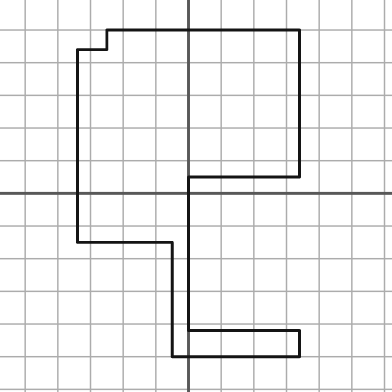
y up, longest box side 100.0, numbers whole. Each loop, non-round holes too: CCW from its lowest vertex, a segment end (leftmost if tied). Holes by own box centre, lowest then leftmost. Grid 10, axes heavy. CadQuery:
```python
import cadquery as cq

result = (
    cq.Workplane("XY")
    .moveTo(-5.0, -50.0)
    .lineTo(34.0, -50.0)
    .lineTo(34.0, -42.0)
    .lineTo(0.0, -42.0)
    .lineTo(0.0, 5.0)
    .lineTo(34.0, 5.0)
    .lineTo(34.0, 50.0)
    .lineTo(-25.0, 50.0)
    .lineTo(-25.0, 44.0)
    .lineTo(-34.0, 44.0)
    .lineTo(-34.0, -15.0)
    .lineTo(-5.0, -15.0)
    .close()
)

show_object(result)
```